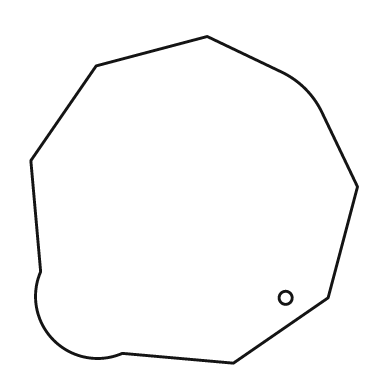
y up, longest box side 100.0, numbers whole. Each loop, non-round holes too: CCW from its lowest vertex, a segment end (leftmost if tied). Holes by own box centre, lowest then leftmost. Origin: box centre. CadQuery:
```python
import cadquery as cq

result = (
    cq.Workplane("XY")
    .moveTo(12.0, -50.0)
    .lineTo(41.0, -30.0)
    .lineTo(50.0, 4.0)
    .lineTo(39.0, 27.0)
    .threePointArc((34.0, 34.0), (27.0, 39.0))
    .lineTo(4.0, 50.0)
    .lineTo(-30.0, 41.0)
    .lineTo(-50.0, 12.0)
    .lineTo(-47.0, -22.0)
    .threePointArc((-43.0, -43.0), (-22.0, -47.0))
    .close()
    .moveTo(28.0, -30.0)
    .circle(2.0)
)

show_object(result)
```